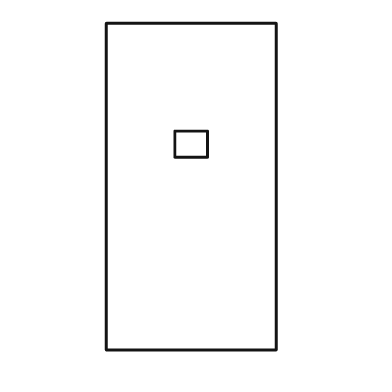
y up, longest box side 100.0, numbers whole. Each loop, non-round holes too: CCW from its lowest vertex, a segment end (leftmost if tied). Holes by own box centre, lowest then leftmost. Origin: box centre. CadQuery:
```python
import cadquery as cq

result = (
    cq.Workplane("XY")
    .moveTo(-26.0, -50.0)
    .lineTo(26.0, -50.0)
    .lineTo(26.0, 50.0)
    .lineTo(-26.0, 50.0)
    .close()
    .moveTo(-5.0, 9.0)
    .lineTo(5.0, 9.0)
    .lineTo(5.0, 17.0)
    .lineTo(-5.0, 17.0)
    .close()
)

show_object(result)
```